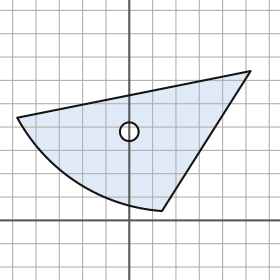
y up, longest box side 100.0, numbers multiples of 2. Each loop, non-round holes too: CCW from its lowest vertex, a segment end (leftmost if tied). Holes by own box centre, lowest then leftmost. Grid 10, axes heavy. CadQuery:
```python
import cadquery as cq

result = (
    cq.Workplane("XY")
    .moveTo(14.0, 4.0)
    .lineTo(52.0, 64.0)
    .lineTo(-48.0, 44.0)
    .threePointArc((-22.0, 16.0), (14.0, 4.0))
    .close()
    .moveTo(0.0, 38.0)
    .circle(4.0)
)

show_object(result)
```